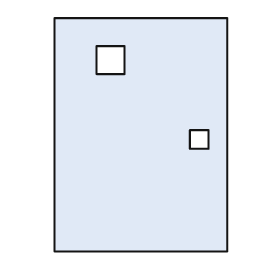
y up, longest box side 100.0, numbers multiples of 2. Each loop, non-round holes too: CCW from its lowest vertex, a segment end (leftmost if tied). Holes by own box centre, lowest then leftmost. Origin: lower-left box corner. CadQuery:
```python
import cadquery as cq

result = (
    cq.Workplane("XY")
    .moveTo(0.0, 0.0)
    .lineTo(74.0, 0.0)
    .lineTo(74.0, 100.0)
    .lineTo(0.0, 100.0)
    .close()
    .moveTo(58.0, 44.0)
    .lineTo(66.0, 44.0)
    .lineTo(66.0, 52.0)
    .lineTo(58.0, 52.0)
    .close()
    .moveTo(18.0, 76.0)
    .lineTo(30.0, 76.0)
    .lineTo(30.0, 88.0)
    .lineTo(18.0, 88.0)
    .close()
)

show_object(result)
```